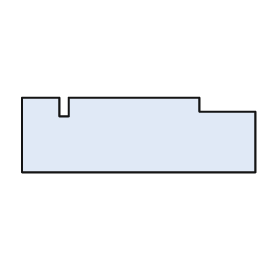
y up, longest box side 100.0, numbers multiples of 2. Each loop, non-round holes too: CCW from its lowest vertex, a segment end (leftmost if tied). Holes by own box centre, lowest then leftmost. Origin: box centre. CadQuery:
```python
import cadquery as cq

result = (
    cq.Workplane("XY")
    .moveTo(-50.0, -16.0)
    .lineTo(50.0, -16.0)
    .lineTo(50.0, 10.0)
    .lineTo(26.0, 10.0)
    .lineTo(26.0, 16.0)
    .lineTo(-30.0, 16.0)
    .lineTo(-30.0, 8.0)
    .lineTo(-34.0, 8.0)
    .lineTo(-34.0, 16.0)
    .lineTo(-50.0, 16.0)
    .close()
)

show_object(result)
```